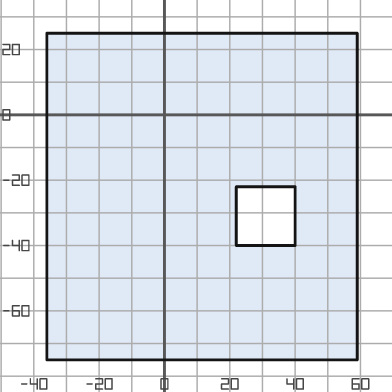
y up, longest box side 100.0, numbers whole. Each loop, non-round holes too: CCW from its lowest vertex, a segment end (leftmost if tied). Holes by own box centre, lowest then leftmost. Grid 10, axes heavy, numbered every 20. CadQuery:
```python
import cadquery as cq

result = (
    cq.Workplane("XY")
    .moveTo(-36.0, -75.0)
    .lineTo(59.0, -75.0)
    .lineTo(59.0, 25.0)
    .lineTo(-36.0, 25.0)
    .close()
    .moveTo(22.0, -40.0)
    .lineTo(40.0, -40.0)
    .lineTo(40.0, -22.0)
    .lineTo(22.0, -22.0)
    .close()
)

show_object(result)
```